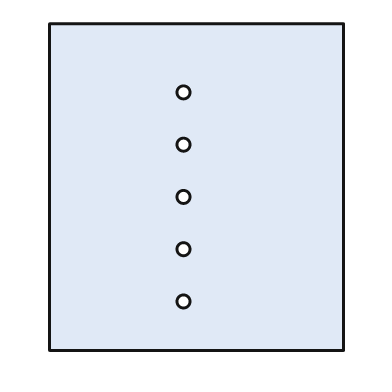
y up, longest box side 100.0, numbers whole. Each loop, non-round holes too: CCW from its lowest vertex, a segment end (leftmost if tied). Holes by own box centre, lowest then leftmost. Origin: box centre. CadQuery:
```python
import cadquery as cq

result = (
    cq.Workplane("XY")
    .moveTo(-45.0, -50.0)
    .lineTo(45.0, -50.0)
    .lineTo(45.0, 50.0)
    .lineTo(-45.0, 50.0)
    .close()
    .moveTo(-4.0, -35.0)
    .circle(2.0)
    .moveTo(-4.0, -19.0)
    .circle(2.0)
    .moveTo(-4.0, -3.0)
    .circle(2.0)
    .moveTo(-4.0, 13.0)
    .circle(2.0)
    .moveTo(-4.0, 29.0)
    .circle(2.0)
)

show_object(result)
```